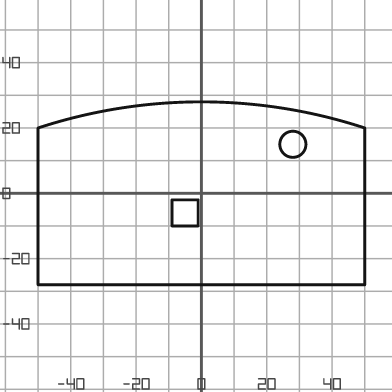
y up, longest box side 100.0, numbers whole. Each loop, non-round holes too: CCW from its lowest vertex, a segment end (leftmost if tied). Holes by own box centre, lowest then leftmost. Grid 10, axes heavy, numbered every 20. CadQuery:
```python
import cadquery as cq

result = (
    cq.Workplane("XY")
    .moveTo(-50.0, -28.0)
    .lineTo(50.0, -28.0)
    .lineTo(50.0, 20.0)
    .threePointArc((0.0, 28.0), (-50.0, 20.0))
    .close()
    .moveTo(-9.0, -10.0)
    .lineTo(-1.0, -10.0)
    .lineTo(-1.0, -2.0)
    .lineTo(-9.0, -2.0)
    .close()
    .moveTo(28.0, 15.0)
    .circle(4.0)
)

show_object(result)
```